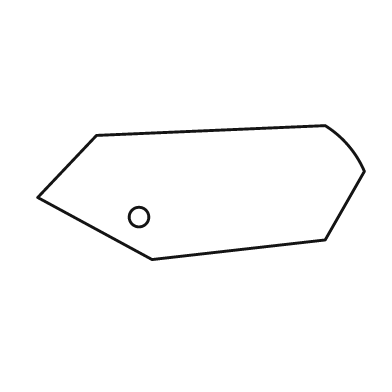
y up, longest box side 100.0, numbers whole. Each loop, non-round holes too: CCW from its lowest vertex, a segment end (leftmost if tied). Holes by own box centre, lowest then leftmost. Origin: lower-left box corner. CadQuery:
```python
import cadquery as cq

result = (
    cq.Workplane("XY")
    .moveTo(35.0, 0.0)
    .lineTo(88.0, 6.0)
    .lineTo(100.0, 27.0)
    .threePointArc((95.0, 35.0), (88.0, 41.0))
    .lineTo(18.0, 38.0)
    .lineTo(0.0, 19.0)
    .close()
    .moveTo(31.0, 13.0)
    .circle(3.0)
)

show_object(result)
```